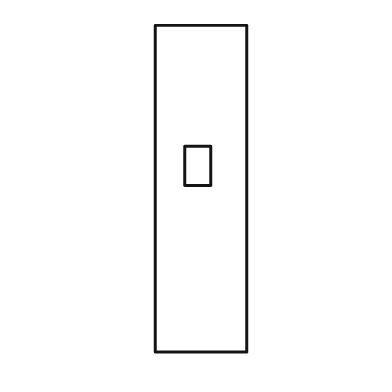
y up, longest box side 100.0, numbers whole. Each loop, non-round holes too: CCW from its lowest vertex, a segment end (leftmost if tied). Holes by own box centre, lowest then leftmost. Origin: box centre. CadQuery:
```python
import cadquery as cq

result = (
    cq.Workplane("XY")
    .moveTo(-14.0, -50.0)
    .lineTo(14.0, -50.0)
    .lineTo(14.0, 50.0)
    .lineTo(-14.0, 50.0)
    .close()
    .moveTo(-5.0, 1.0)
    .lineTo(3.0, 1.0)
    .lineTo(3.0, 13.0)
    .lineTo(-5.0, 13.0)
    .close()
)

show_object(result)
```